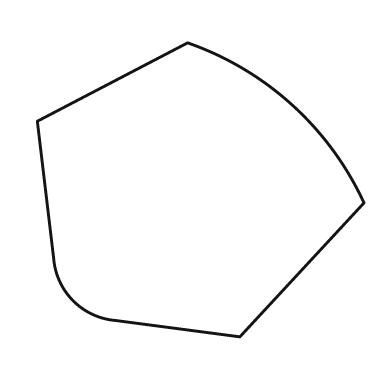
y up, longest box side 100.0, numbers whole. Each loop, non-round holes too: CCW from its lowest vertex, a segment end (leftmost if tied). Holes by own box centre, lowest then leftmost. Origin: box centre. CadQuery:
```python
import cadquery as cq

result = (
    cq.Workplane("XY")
    .moveTo(12.0, -45.0)
    .lineTo(50.0, -4.0)
    .threePointArc((28.0, 26.0), (-4.0, 45.0))
    .lineTo(-50.0, 21.0)
    .lineTo(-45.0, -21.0)
    .threePointArc((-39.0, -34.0), (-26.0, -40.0))
    .close()
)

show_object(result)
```